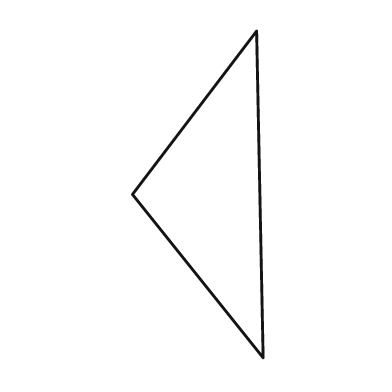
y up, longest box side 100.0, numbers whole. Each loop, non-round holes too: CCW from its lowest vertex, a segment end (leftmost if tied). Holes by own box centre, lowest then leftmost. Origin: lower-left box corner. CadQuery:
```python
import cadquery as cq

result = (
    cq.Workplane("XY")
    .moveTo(40.0, 0.0)
    .lineTo(38.0, 100.0)
    .lineTo(0.0, 50.0)
    .close()
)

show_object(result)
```